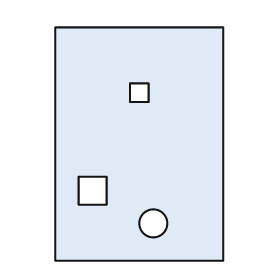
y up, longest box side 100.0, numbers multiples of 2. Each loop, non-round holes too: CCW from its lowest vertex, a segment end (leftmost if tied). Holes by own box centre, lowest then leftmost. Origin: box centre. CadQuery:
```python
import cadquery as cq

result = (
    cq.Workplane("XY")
    .moveTo(-36.0, -50.0)
    .lineTo(36.0, -50.0)
    .lineTo(36.0, 50.0)
    .lineTo(-36.0, 50.0)
    .close()
    .moveTo(6.0, -34.0)
    .circle(6.0)
    .moveTo(-26.0, -26.0)
    .lineTo(-14.0, -26.0)
    .lineTo(-14.0, -14.0)
    .lineTo(-26.0, -14.0)
    .close()
    .moveTo(-4.0, 18.0)
    .lineTo(4.0, 18.0)
    .lineTo(4.0, 26.0)
    .lineTo(-4.0, 26.0)
    .close()
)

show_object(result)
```